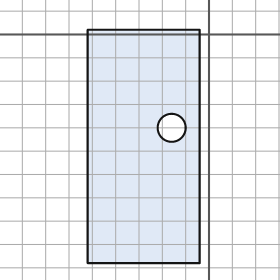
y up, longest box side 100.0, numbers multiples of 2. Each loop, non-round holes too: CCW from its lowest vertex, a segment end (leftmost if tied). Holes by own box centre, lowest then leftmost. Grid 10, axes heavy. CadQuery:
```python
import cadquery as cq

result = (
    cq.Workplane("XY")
    .moveTo(-52.0, -98.0)
    .lineTo(-4.0, -98.0)
    .lineTo(-4.0, 2.0)
    .lineTo(-52.0, 2.0)
    .close()
    .moveTo(-16.0, -40.0)
    .circle(6.0)
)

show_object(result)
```